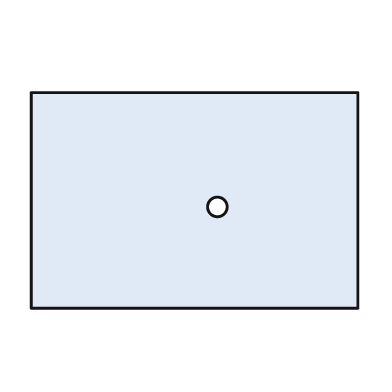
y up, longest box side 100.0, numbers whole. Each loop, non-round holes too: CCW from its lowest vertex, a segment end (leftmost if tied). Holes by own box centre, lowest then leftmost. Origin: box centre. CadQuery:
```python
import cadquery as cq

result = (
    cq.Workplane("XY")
    .moveTo(-50.0, -33.0)
    .lineTo(50.0, -33.0)
    .lineTo(50.0, 33.0)
    .lineTo(-50.0, 33.0)
    .close()
    .moveTo(7.0, -2.0)
    .circle(3.0)
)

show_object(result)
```